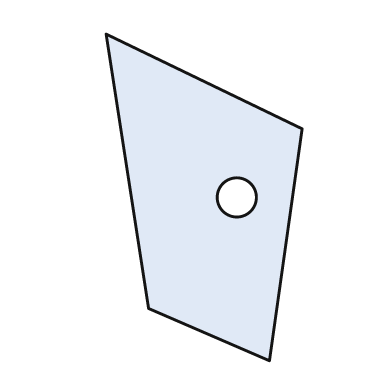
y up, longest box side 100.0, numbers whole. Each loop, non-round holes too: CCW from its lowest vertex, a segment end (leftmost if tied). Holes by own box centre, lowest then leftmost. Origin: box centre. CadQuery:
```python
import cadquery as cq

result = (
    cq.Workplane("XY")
    .moveTo(20.0, -50.0)
    .lineTo(30.0, 21.0)
    .lineTo(-30.0, 50.0)
    .lineTo(-17.0, -34.0)
    .close()
    .moveTo(10.0, 0.0)
    .circle(6.0)
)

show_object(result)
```